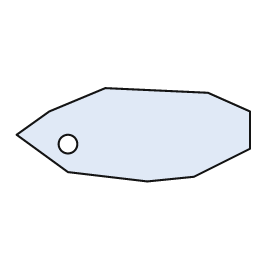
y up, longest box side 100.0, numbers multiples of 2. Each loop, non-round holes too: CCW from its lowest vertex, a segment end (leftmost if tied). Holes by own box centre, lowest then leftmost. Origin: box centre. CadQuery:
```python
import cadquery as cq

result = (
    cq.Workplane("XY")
    .moveTo(6.0, -20.0)
    .lineTo(26.0, -18.0)
    .lineTo(50.0, -6.0)
    .lineTo(50.0, 10.0)
    .lineTo(32.0, 18.0)
    .lineTo(-12.0, 20.0)
    .lineTo(-36.0, 10.0)
    .lineTo(-50.0, 0.0)
    .lineTo(-28.0, -16.0)
    .close()
    .moveTo(-28.0, -4.0)
    .circle(4.0)
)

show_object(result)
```